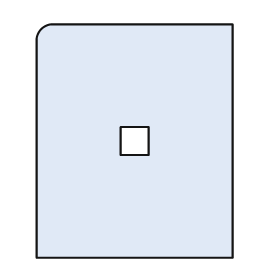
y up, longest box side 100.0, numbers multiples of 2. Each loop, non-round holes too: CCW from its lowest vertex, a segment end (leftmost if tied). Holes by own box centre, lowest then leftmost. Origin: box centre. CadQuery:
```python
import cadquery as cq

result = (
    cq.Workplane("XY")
    .moveTo(-42.0, -50.0)
    .lineTo(42.0, -50.0)
    .lineTo(42.0, 50.0)
    .lineTo(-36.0, 50.0)
    .threePointArc((-40.0, 48.0), (-42.0, 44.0))
    .close()
    .moveTo(-6.0, -6.0)
    .lineTo(6.0, -6.0)
    .lineTo(6.0, 6.0)
    .lineTo(-6.0, 6.0)
    .close()
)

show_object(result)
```